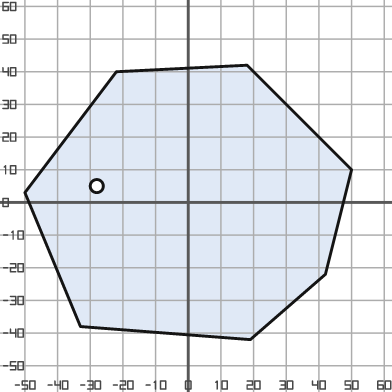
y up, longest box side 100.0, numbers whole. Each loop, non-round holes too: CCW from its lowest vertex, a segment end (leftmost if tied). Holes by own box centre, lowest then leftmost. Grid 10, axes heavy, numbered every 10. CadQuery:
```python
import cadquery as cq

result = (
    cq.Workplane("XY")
    .moveTo(19.0, -42.0)
    .lineTo(42.0, -22.0)
    .lineTo(50.0, 10.0)
    .lineTo(18.0, 42.0)
    .lineTo(-22.0, 40.0)
    .lineTo(-50.0, 3.0)
    .lineTo(-33.0, -38.0)
    .close()
    .moveTo(-28.0, 5.0)
    .circle(2.0)
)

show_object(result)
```